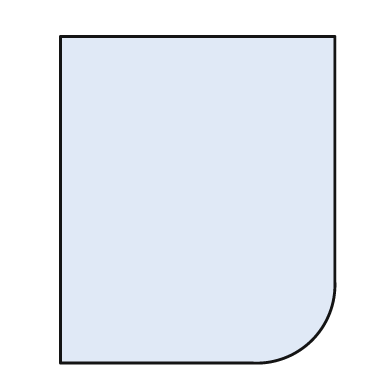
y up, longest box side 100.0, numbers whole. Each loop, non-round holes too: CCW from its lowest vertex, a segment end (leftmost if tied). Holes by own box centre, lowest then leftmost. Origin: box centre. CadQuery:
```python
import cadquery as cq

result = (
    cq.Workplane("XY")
    .moveTo(-42.0, -50.0)
    .lineTo(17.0, -50.0)
    .threePointArc((35.0, -43.0), (42.0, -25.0))
    .lineTo(42.0, 50.0)
    .lineTo(-42.0, 50.0)
    .close()
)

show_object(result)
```